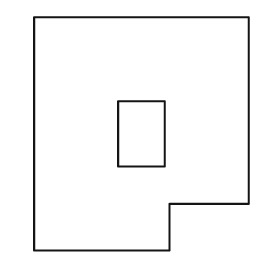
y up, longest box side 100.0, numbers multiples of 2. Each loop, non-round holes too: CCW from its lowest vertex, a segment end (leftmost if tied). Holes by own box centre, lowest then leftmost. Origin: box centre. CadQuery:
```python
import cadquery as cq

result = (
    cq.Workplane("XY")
    .moveTo(-46.0, -50.0)
    .lineTo(12.0, -50.0)
    .lineTo(12.0, -30.0)
    .lineTo(46.0, -30.0)
    .lineTo(46.0, 50.0)
    .lineTo(-46.0, 50.0)
    .close()
    .moveTo(-10.0, -14.0)
    .lineTo(10.0, -14.0)
    .lineTo(10.0, 14.0)
    .lineTo(-10.0, 14.0)
    .close()
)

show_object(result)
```